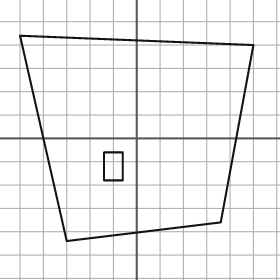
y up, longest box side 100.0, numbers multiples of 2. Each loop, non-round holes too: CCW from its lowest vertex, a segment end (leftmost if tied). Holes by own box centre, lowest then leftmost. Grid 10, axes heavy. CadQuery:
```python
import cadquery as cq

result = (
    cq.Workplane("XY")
    .moveTo(-30.0, -44.0)
    .lineTo(36.0, -36.0)
    .lineTo(50.0, 40.0)
    .lineTo(-50.0, 44.0)
    .close()
    .moveTo(-14.0, -18.0)
    .lineTo(-6.0, -18.0)
    .lineTo(-6.0, -6.0)
    .lineTo(-14.0, -6.0)
    .close()
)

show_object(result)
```